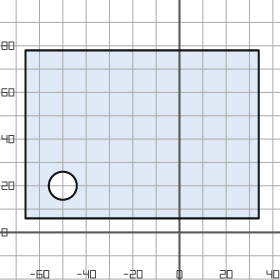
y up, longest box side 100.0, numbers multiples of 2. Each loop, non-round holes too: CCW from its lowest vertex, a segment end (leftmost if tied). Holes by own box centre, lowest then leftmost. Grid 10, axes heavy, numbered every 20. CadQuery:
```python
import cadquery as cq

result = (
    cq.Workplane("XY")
    .moveTo(-66.0, 6.0)
    .lineTo(34.0, 6.0)
    .lineTo(34.0, 78.0)
    .lineTo(-66.0, 78.0)
    .close()
    .moveTo(-50.0, 20.0)
    .circle(6.0)
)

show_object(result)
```